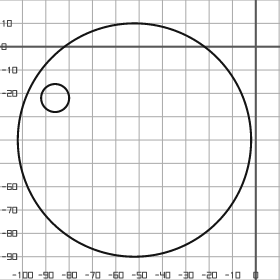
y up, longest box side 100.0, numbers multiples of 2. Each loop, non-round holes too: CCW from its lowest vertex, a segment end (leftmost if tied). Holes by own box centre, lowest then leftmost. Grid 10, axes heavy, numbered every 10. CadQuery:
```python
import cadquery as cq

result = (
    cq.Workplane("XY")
    .moveTo(-52.0, -40.0)
    .circle(50.0)
    .moveTo(-86.0, -22.0)
    .circle(6.0)
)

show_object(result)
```